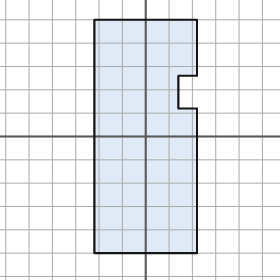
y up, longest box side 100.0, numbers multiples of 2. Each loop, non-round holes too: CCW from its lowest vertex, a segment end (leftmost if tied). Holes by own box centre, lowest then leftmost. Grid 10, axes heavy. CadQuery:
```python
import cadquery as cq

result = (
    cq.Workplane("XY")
    .moveTo(-22.0, -50.0)
    .lineTo(22.0, -50.0)
    .lineTo(22.0, 12.0)
    .lineTo(14.0, 12.0)
    .lineTo(14.0, 26.0)
    .lineTo(22.0, 26.0)
    .lineTo(22.0, 50.0)
    .lineTo(-22.0, 50.0)
    .close()
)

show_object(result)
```